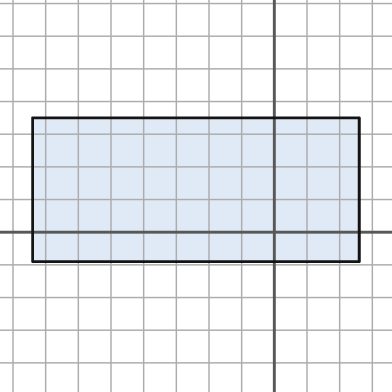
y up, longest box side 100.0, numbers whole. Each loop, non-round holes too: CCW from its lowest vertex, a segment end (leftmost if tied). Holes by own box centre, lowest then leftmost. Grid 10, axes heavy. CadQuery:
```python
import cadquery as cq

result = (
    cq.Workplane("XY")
    .moveTo(-74.0, -9.0)
    .lineTo(26.0, -9.0)
    .lineTo(26.0, 35.0)
    .lineTo(-74.0, 35.0)
    .close()
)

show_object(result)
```